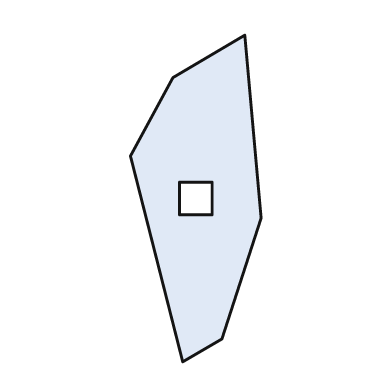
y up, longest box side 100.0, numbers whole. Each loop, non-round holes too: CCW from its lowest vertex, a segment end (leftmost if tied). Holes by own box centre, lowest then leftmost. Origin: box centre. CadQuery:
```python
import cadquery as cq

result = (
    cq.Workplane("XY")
    .moveTo(-4.0, -50.0)
    .lineTo(8.0, -43.0)
    .lineTo(20.0, -6.0)
    .lineTo(15.0, 50.0)
    .lineTo(-7.0, 37.0)
    .lineTo(-20.0, 13.0)
    .close()
    .moveTo(-5.0, -5.0)
    .lineTo(5.0, -5.0)
    .lineTo(5.0, 5.0)
    .lineTo(-5.0, 5.0)
    .close()
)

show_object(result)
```